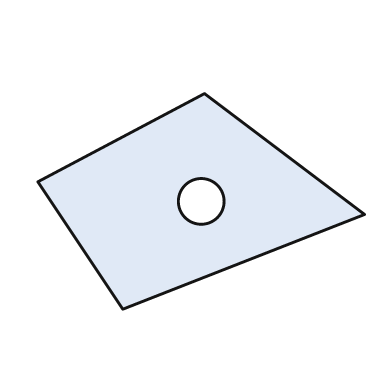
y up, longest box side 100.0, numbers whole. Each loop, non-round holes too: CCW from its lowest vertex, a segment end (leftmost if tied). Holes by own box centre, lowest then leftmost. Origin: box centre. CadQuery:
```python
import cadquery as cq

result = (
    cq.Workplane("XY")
    .moveTo(-24.0, -33.0)
    .lineTo(50.0, -4.0)
    .lineTo(1.0, 33.0)
    .lineTo(-50.0, 6.0)
    .close()
    .moveTo(0.0, 0.0)
    .circle(7.0)
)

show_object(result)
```